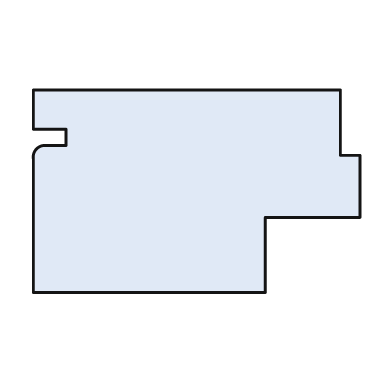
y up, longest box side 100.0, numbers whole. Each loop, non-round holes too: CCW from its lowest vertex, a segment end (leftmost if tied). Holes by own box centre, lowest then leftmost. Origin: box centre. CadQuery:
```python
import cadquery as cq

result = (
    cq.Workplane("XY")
    .moveTo(-50.0, -31.0)
    .lineTo(21.0, -31.0)
    .lineTo(21.0, -8.0)
    .lineTo(50.0, -8.0)
    .lineTo(50.0, 11.0)
    .lineTo(44.0, 11.0)
    .lineTo(44.0, 31.0)
    .lineTo(-50.0, 31.0)
    .lineTo(-50.0, 19.0)
    .lineTo(-40.0, 19.0)
    .lineTo(-40.0, 14.0)
    .lineTo(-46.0, 14.0)
    .threePointArc((-49.0, 13.0), (-50.0, 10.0))
    .close()
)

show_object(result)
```